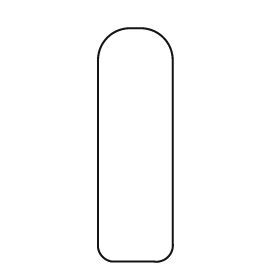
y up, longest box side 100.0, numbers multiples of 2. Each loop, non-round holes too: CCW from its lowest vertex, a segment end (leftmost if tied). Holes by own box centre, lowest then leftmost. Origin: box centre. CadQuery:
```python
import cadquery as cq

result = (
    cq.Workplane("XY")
    .moveTo(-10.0, -50.0)
    .lineTo(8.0, -50.0)
    .threePointArc((14.0, -48.0), (16.0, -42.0))
    .lineTo(16.0, 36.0)
    .threePointArc((12.0, 46.0), (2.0, 50.0))
    .lineTo(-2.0, 50.0)
    .threePointArc((-12.0, 46.0), (-16.0, 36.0))
    .lineTo(-16.0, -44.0)
    .threePointArc((-14.0, -48.0), (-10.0, -50.0))
    .close()
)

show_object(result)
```